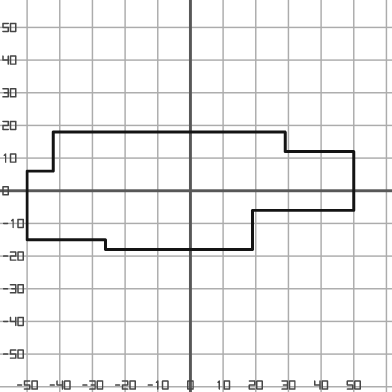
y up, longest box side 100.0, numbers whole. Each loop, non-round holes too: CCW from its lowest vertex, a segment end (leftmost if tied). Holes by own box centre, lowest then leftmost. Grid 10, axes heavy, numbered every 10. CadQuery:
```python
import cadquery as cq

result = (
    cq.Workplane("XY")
    .moveTo(-26.0, -18.0)
    .lineTo(19.0, -18.0)
    .lineTo(19.0, -6.0)
    .lineTo(50.0, -6.0)
    .lineTo(50.0, 12.0)
    .lineTo(29.0, 12.0)
    .lineTo(29.0, 18.0)
    .lineTo(-42.0, 18.0)
    .lineTo(-42.0, 6.0)
    .lineTo(-50.0, 6.0)
    .lineTo(-50.0, -15.0)
    .lineTo(-26.0, -15.0)
    .close()
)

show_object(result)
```